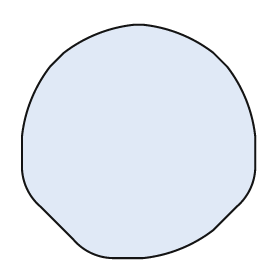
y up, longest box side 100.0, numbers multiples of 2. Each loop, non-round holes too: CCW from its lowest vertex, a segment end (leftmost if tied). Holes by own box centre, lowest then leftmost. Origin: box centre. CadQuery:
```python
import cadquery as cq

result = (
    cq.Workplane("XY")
    .moveTo(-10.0, -50.0)
    .lineTo(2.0, -50.0)
    .threePointArc((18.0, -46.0), (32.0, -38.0))
    .lineTo(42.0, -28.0)
    .threePointArc((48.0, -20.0), (50.0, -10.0))
    .lineTo(50.0, 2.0)
    .threePointArc((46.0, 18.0), (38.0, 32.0))
    .lineTo(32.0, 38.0)
    .threePointArc((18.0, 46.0), (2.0, 50.0))
    .lineTo(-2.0, 50.0)
    .threePointArc((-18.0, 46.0), (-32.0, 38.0))
    .lineTo(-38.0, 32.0)
    .threePointArc((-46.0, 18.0), (-50.0, 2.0))
    .lineTo(-50.0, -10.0)
    .threePointArc((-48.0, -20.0), (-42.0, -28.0))
    .lineTo(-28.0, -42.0)
    .threePointArc((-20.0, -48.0), (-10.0, -50.0))
    .close()
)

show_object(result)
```